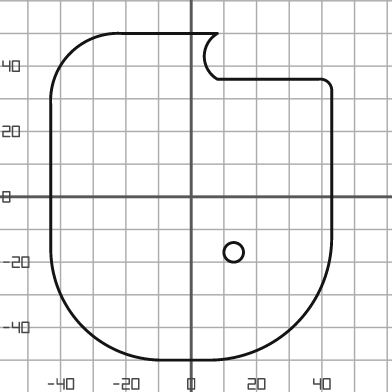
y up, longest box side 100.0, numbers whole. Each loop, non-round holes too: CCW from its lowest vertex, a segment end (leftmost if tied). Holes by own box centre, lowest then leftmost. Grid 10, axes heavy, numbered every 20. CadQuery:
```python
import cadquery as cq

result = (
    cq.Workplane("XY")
    .moveTo(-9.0, -50.0)
    .lineTo(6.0, -50.0)
    .threePointArc((32.0, -39.0), (43.0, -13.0))
    .lineTo(43.0, 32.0)
    .threePointArc((42.0, 35.0), (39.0, 36.0))
    .lineTo(8.0, 36.0)
    .threePointArc((4.0, 43.0), (8.0, 50.0))
    .lineTo(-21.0, 50.0)
    .threePointArc((-37.0, 44.0), (-43.0, 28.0))
    .lineTo(-43.0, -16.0)
    .threePointArc((-33.0, -40.0), (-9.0, -50.0))
    .close()
    .moveTo(13.0, -17.0)
    .circle(3.0)
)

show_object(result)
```